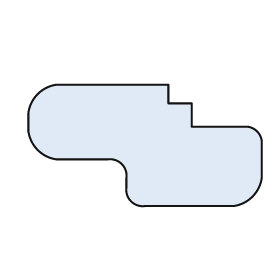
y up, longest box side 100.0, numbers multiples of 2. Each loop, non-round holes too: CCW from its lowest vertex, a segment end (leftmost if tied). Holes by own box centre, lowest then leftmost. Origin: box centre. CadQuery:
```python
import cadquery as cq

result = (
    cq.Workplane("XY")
    .moveTo(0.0, -26.0)
    .lineTo(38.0, -26.0)
    .threePointArc((46.0, -22.0), (50.0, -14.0))
    .lineTo(50.0, 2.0)
    .threePointArc((48.0, 6.0), (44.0, 8.0))
    .lineTo(20.0, 8.0)
    .lineTo(20.0, 18.0)
    .lineTo(10.0, 18.0)
    .lineTo(10.0, 26.0)
    .lineTo(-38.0, 26.0)
    .threePointArc((-46.0, 22.0), (-50.0, 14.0))
    .lineTo(-50.0, 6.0)
    .threePointArc((-46.0, -2.0), (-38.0, -6.0))
    .lineTo(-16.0, -6.0)
    .threePointArc((-10.0, -8.0), (-8.0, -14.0))
    .lineTo(-8.0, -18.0)
    .threePointArc((-6.0, -24.0), (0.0, -26.0))
    .close()
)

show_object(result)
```